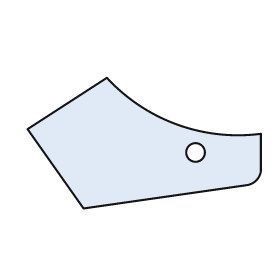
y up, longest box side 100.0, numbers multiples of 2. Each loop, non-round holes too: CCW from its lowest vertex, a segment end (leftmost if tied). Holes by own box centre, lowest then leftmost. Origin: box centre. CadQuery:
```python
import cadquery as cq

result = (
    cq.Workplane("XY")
    .moveTo(-26.0, -28.0)
    .lineTo(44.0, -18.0)
    .threePointArc((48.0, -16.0), (50.0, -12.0))
    .lineTo(50.0, 4.0)
    .threePointArc((14.0, 8.0), (-16.0, 28.0))
    .lineTo(-50.0, 6.0)
    .close()
    .moveTo(22.0, -4.0)
    .circle(4.0)
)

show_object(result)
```